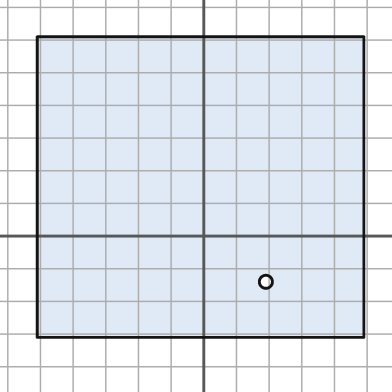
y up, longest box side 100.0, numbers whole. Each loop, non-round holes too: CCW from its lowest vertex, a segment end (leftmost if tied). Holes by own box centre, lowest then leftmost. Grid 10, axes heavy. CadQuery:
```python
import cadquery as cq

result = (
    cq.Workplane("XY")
    .moveTo(-51.0, -31.0)
    .lineTo(49.0, -31.0)
    .lineTo(49.0, 61.0)
    .lineTo(-51.0, 61.0)
    .close()
    .moveTo(19.0, -14.0)
    .circle(2.0)
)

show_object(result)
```